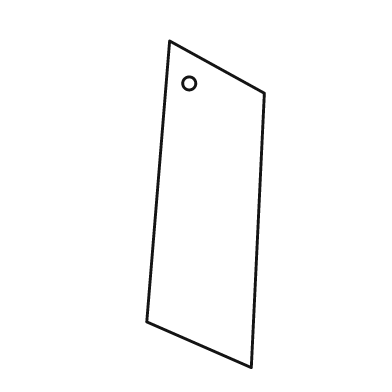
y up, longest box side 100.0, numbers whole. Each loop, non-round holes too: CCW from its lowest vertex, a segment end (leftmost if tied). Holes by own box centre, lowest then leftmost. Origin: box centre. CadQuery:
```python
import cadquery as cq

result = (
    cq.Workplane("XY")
    .moveTo(14.0, -50.0)
    .lineTo(18.0, 34.0)
    .lineTo(-11.0, 50.0)
    .lineTo(-18.0, -36.0)
    .close()
    .moveTo(-5.0, 37.0)
    .circle(2.0)
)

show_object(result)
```